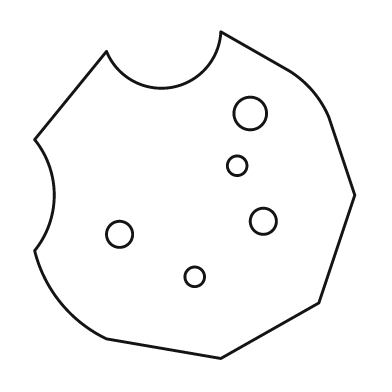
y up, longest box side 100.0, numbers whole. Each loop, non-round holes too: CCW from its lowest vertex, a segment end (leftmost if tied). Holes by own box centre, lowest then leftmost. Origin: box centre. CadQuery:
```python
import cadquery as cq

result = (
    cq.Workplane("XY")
    .moveTo(8.0, -50.0)
    .lineTo(38.0, -33.0)
    .lineTo(49.0, 0.0)
    .lineTo(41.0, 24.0)
    .threePointArc((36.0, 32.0), (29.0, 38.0))
    .lineTo(8.0, 50.0)
    .threePointArc((-7.0, 33.0), (-27.0, 44.0))
    .lineTo(-49.0, 17.0)
    .threePointArc((-43.0, 0.0), (-49.0, -17.0))
    .threePointArc((-41.0, -33.0), (-27.0, -44.0))
    .close()
    .moveTo(0.0, -25.0)
    .circle(3.0)
    .moveTo(-23.0, -12.0)
    .circle(4.0)
    .moveTo(21.0, -8.0)
    .circle(4.0)
    .moveTo(13.0, 9.0)
    .circle(3.0)
    .moveTo(17.0, 25.0)
    .circle(5.0)
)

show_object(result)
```